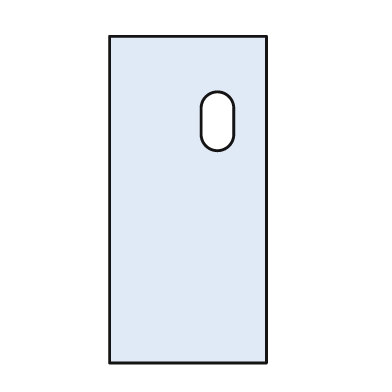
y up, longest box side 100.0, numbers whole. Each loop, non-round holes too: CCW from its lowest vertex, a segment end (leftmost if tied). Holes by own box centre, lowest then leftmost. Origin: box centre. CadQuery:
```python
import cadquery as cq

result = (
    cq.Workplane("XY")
    .moveTo(-24.0, -50.0)
    .lineTo(24.0, -50.0)
    .lineTo(24.0, 50.0)
    .lineTo(-24.0, 50.0)
    .close()
    .moveTo(4.0, 20.0)
    .threePointArc((9.0, 15.0), (14.0, 20.0))
    .lineTo(14.0, 28.0)
    .threePointArc((9.0, 33.0), (4.0, 28.0))
    .close()
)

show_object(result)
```